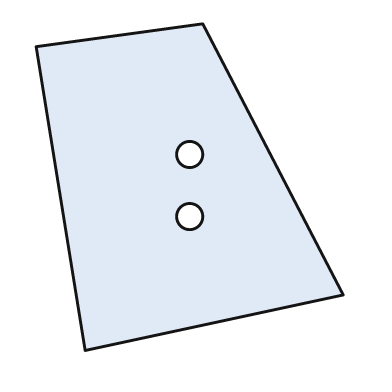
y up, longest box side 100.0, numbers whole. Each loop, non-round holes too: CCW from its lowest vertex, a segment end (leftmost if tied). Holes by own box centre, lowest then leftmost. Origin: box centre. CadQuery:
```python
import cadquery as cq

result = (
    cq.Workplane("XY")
    .moveTo(-32.0, -50.0)
    .lineTo(47.0, -33.0)
    .lineTo(4.0, 50.0)
    .lineTo(-47.0, 43.0)
    .close()
    .moveTo(0.0, -9.0)
    .circle(4.0)
    .moveTo(0.0, 10.0)
    .circle(4.0)
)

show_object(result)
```